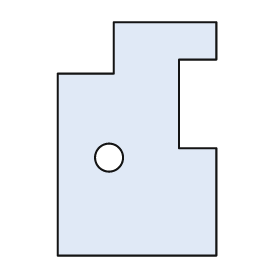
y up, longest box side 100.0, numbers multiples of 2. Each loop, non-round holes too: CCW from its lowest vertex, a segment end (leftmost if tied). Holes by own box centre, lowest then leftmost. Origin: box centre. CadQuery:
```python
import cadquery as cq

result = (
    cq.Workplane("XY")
    .moveTo(-34.0, -50.0)
    .lineTo(34.0, -50.0)
    .lineTo(34.0, -4.0)
    .lineTo(18.0, -4.0)
    .lineTo(18.0, 34.0)
    .lineTo(34.0, 34.0)
    .lineTo(34.0, 50.0)
    .lineTo(-10.0, 50.0)
    .lineTo(-10.0, 28.0)
    .lineTo(-34.0, 28.0)
    .close()
    .moveTo(-12.0, -8.0)
    .circle(6.0)
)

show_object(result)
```